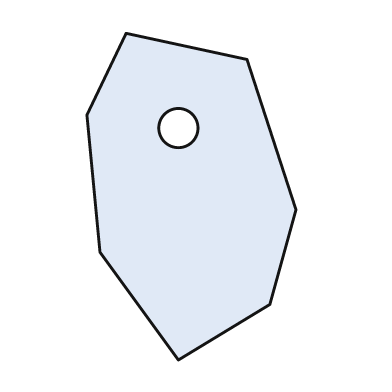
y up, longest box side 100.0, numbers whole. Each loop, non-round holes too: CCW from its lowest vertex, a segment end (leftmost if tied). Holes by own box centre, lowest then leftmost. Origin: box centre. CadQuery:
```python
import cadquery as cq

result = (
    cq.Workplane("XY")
    .moveTo(-4.0, -50.0)
    .lineTo(24.0, -33.0)
    .lineTo(32.0, -4.0)
    .lineTo(17.0, 42.0)
    .lineTo(-20.0, 50.0)
    .lineTo(-32.0, 25.0)
    .lineTo(-28.0, -17.0)
    .close()
    .moveTo(-4.0, 21.0)
    .circle(6.0)
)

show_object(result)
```